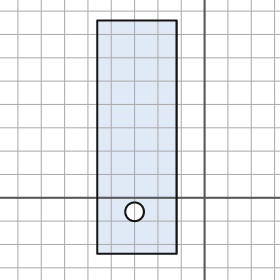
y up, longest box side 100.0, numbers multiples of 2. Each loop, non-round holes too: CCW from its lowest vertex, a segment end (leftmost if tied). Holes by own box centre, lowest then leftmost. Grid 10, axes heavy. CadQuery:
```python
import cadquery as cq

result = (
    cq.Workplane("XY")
    .moveTo(-46.0, -24.0)
    .lineTo(-12.0, -24.0)
    .lineTo(-12.0, 76.0)
    .lineTo(-46.0, 76.0)
    .close()
    .moveTo(-30.0, -6.0)
    .circle(4.0)
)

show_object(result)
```